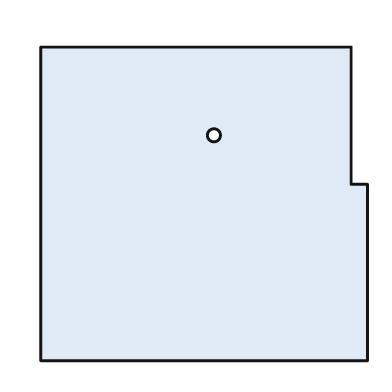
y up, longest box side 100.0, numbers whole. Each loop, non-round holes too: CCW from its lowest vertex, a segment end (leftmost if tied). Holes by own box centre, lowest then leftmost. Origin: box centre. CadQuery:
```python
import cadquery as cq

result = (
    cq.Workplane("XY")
    .moveTo(-50.0, -48.0)
    .lineTo(50.0, -48.0)
    .lineTo(50.0, 6.0)
    .lineTo(45.0, 6.0)
    .lineTo(45.0, 48.0)
    .lineTo(-50.0, 48.0)
    .close()
    .moveTo(3.0, 21.0)
    .circle(2.0)
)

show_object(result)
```